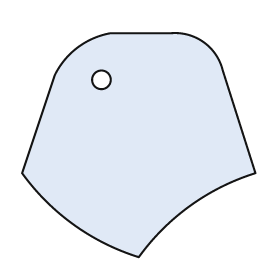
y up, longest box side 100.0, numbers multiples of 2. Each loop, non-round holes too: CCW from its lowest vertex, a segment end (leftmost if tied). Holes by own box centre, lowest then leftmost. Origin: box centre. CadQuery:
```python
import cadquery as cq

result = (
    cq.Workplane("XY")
    .moveTo(0.0, -48.0)
    .threePointArc((22.0, -26.0), (50.0, -12.0))
    .lineTo(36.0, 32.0)
    .threePointArc((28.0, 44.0), (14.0, 48.0))
    .lineTo(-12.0, 48.0)
    .threePointArc((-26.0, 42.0), (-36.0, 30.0))
    .lineTo(-50.0, -12.0)
    .threePointArc((-28.0, -34.0), (0.0, -48.0))
    .close()
    .moveTo(-16.0, 28.0)
    .circle(4.0)
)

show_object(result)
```